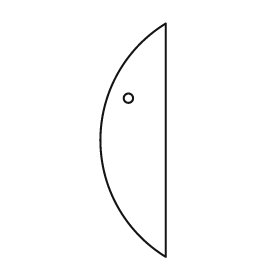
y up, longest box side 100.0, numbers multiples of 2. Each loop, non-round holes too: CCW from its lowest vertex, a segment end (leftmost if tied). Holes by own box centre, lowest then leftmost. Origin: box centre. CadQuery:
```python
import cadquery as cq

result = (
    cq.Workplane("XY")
    .moveTo(14.0, -50.0)
    .lineTo(14.0, 50.0)
    .threePointArc((-14.0, 0.0), (14.0, -50.0))
    .close()
    .moveTo(-2.0, 18.0)
    .circle(2.0)
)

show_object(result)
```